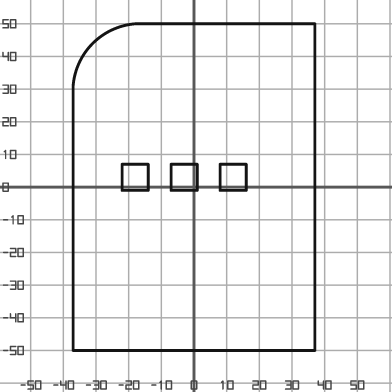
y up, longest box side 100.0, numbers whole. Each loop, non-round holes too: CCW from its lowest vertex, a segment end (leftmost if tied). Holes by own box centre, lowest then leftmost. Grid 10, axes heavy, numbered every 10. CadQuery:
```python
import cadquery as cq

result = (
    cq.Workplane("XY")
    .moveTo(-37.0, -50.0)
    .lineTo(37.0, -50.0)
    .lineTo(37.0, 50.0)
    .lineTo(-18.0, 50.0)
    .threePointArc((-31.0, 44.0), (-37.0, 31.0))
    .close()
    .moveTo(-22.0, -1.0)
    .lineTo(-14.0, -1.0)
    .lineTo(-14.0, 7.0)
    .lineTo(-22.0, 7.0)
    .close()
    .moveTo(-7.0, -1.0)
    .lineTo(1.0, -1.0)
    .lineTo(1.0, 7.0)
    .lineTo(-7.0, 7.0)
    .close()
    .moveTo(8.0, -1.0)
    .lineTo(16.0, -1.0)
    .lineTo(16.0, 7.0)
    .lineTo(8.0, 7.0)
    .close()
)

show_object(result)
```